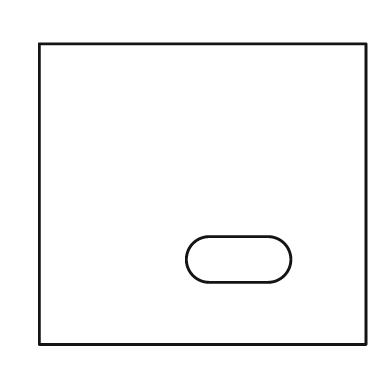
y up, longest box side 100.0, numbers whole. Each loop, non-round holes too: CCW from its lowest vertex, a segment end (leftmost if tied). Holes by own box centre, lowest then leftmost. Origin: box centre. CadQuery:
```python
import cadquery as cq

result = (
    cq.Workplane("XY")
    .moveTo(-50.0, -46.0)
    .lineTo(50.0, -46.0)
    .lineTo(50.0, 46.0)
    .lineTo(-50.0, 46.0)
    .close()
    .moveTo(2.0, -27.0)
    .lineTo(20.0, -27.0)
    .threePointArc((27.0, -20.0), (20.0, -13.0))
    .lineTo(2.0, -13.0)
    .threePointArc((-5.0, -20.0), (2.0, -27.0))
    .close()
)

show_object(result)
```